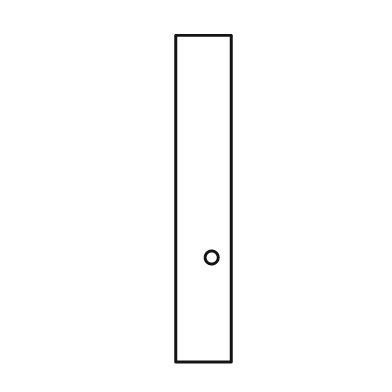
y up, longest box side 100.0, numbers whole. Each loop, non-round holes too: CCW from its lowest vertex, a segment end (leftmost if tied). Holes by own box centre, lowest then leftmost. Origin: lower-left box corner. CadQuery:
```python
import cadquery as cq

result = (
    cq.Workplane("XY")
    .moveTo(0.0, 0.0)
    .lineTo(17.0, 0.0)
    .lineTo(17.0, 100.0)
    .lineTo(0.0, 100.0)
    .close()
    .moveTo(11.0, 32.0)
    .circle(2.0)
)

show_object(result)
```